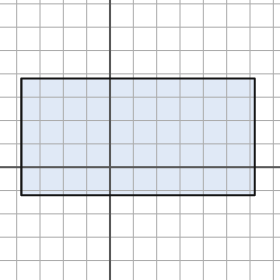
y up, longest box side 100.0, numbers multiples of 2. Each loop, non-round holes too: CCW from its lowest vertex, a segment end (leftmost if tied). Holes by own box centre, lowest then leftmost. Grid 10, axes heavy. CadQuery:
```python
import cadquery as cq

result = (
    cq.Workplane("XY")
    .moveTo(-38.0, -12.0)
    .lineTo(62.0, -12.0)
    .lineTo(62.0, 38.0)
    .lineTo(-38.0, 38.0)
    .close()
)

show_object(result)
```